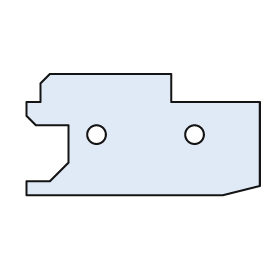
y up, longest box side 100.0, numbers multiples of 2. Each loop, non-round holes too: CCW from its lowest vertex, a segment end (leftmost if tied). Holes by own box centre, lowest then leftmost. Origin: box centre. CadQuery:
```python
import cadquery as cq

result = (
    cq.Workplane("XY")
    .moveTo(-50.0, -26.0)
    .lineTo(34.0, -26.0)
    .lineTo(50.0, -22.0)
    .lineTo(50.0, 14.0)
    .lineTo(12.0, 14.0)
    .lineTo(12.0, 26.0)
    .lineTo(-40.0, 26.0)
    .lineTo(-44.0, 22.0)
    .lineTo(-44.0, 14.0)
    .lineTo(-50.0, 14.0)
    .lineTo(-50.0, 8.0)
    .lineTo(-46.0, 4.0)
    .lineTo(-32.0, 4.0)
    .lineTo(-32.0, -12.0)
    .lineTo(-40.0, -20.0)
    .lineTo(-50.0, -20.0)
    .close()
    .moveTo(-20.0, 0.0)
    .circle(4.0)
    .moveTo(22.0, 0.0)
    .circle(4.0)
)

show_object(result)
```